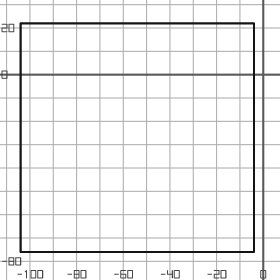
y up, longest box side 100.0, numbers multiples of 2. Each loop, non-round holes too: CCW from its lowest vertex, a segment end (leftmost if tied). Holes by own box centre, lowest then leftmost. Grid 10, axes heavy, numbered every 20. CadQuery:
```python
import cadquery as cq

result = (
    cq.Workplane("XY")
    .moveTo(-104.0, -76.0)
    .lineTo(-4.0, -76.0)
    .lineTo(-4.0, 22.0)
    .lineTo(-104.0, 22.0)
    .close()
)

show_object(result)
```